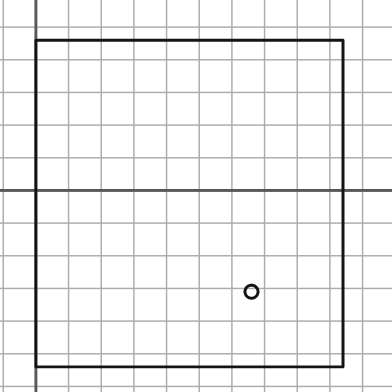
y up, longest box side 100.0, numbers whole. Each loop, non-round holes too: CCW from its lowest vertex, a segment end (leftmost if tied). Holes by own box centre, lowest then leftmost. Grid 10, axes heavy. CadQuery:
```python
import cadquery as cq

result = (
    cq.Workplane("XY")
    .moveTo(0.0, -54.0)
    .lineTo(94.0, -54.0)
    .lineTo(94.0, 46.0)
    .lineTo(0.0, 46.0)
    .close()
    .moveTo(66.0, -31.0)
    .circle(2.0)
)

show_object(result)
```